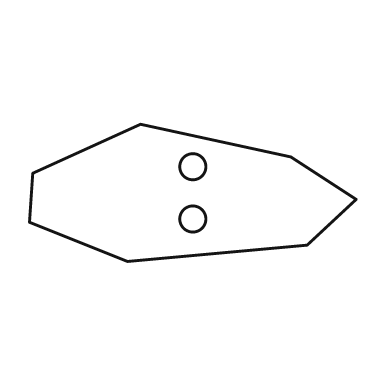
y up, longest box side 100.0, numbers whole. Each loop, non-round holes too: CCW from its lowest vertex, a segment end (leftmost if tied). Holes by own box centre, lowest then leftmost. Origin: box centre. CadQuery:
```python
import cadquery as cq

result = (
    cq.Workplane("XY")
    .moveTo(-20.0, -21.0)
    .lineTo(35.0, -16.0)
    .lineTo(50.0, -2.0)
    .lineTo(30.0, 11.0)
    .lineTo(-16.0, 21.0)
    .lineTo(-49.0, 6.0)
    .lineTo(-50.0, -9.0)
    .close()
    .moveTo(0.0, -8.0)
    .circle(4.0)
    .moveTo(0.0, 8.0)
    .circle(4.0)
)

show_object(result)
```